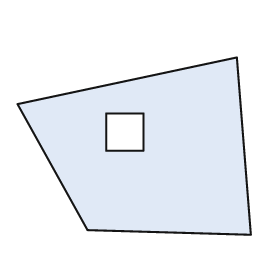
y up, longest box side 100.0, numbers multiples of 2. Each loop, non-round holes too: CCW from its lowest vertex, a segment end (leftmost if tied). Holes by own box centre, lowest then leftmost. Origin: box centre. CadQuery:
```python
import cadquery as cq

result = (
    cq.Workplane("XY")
    .moveTo(50.0, -38.0)
    .lineTo(44.0, 38.0)
    .lineTo(-50.0, 18.0)
    .lineTo(-20.0, -36.0)
    .close()
    .moveTo(-12.0, -2.0)
    .lineTo(4.0, -2.0)
    .lineTo(4.0, 14.0)
    .lineTo(-12.0, 14.0)
    .close()
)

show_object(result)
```